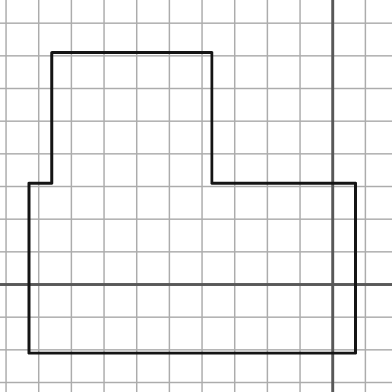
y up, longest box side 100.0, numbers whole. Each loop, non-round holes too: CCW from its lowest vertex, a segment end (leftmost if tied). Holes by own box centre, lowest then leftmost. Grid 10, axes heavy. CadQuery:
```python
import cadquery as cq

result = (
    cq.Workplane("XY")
    .moveTo(-93.0, -21.0)
    .lineTo(7.0, -21.0)
    .lineTo(7.0, 31.0)
    .lineTo(-37.0, 31.0)
    .lineTo(-37.0, 71.0)
    .lineTo(-86.0, 71.0)
    .lineTo(-86.0, 31.0)
    .lineTo(-93.0, 31.0)
    .close()
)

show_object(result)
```